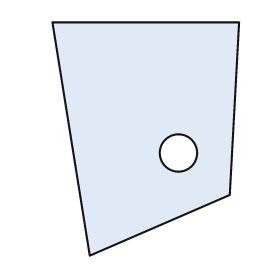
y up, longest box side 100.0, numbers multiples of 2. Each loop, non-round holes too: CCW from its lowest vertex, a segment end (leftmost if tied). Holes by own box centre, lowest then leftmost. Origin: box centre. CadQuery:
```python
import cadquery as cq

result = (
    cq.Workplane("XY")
    .moveTo(-24.0, -50.0)
    .lineTo(36.0, -24.0)
    .lineTo(40.0, 50.0)
    .lineTo(-40.0, 50.0)
    .close()
    .moveTo(14.0, -6.0)
    .circle(8.0)
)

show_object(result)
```